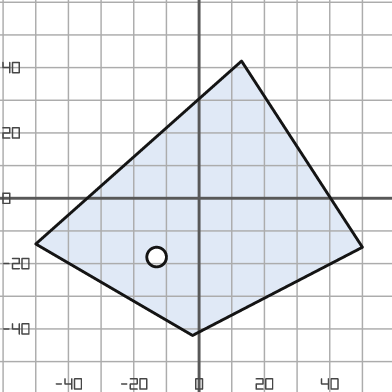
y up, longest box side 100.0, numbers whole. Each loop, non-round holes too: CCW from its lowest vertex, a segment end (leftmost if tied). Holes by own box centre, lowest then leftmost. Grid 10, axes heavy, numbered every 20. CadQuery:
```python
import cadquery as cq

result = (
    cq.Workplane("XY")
    .moveTo(-2.0, -42.0)
    .lineTo(50.0, -15.0)
    .lineTo(13.0, 42.0)
    .lineTo(-50.0, -14.0)
    .close()
    .moveTo(-13.0, -18.0)
    .circle(3.0)
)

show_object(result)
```